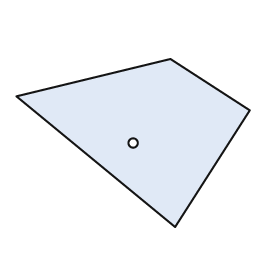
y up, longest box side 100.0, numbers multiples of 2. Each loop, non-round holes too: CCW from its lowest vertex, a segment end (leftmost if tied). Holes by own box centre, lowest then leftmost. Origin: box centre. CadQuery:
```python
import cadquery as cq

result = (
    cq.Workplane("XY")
    .moveTo(18.0, -36.0)
    .lineTo(50.0, 14.0)
    .lineTo(16.0, 36.0)
    .lineTo(-50.0, 20.0)
    .close()
    .moveTo(0.0, 0.0)
    .circle(2.0)
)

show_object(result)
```